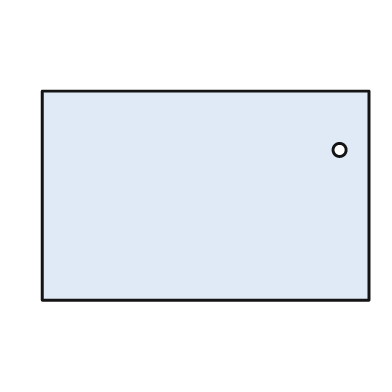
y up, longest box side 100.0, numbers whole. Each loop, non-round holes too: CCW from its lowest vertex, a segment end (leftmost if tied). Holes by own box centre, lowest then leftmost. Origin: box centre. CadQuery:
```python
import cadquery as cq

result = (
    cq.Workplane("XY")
    .moveTo(-50.0, -32.0)
    .lineTo(50.0, -32.0)
    .lineTo(50.0, 32.0)
    .lineTo(-50.0, 32.0)
    .close()
    .moveTo(41.0, 14.0)
    .circle(2.0)
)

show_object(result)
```